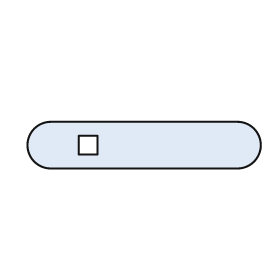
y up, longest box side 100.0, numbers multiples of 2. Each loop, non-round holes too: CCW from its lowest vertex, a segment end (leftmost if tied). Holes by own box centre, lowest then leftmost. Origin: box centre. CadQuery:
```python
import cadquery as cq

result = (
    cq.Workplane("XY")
    .moveTo(-40.0, -10.0)
    .lineTo(40.0, -10.0)
    .threePointArc((50.0, 0.0), (40.0, 10.0))
    .lineTo(-40.0, 10.0)
    .threePointArc((-50.0, 0.0), (-40.0, -10.0))
    .close()
    .moveTo(-28.0, -4.0)
    .lineTo(-20.0, -4.0)
    .lineTo(-20.0, 4.0)
    .lineTo(-28.0, 4.0)
    .close()
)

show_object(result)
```